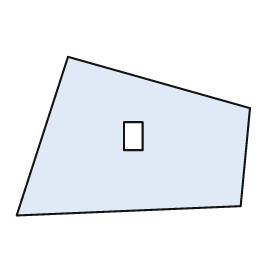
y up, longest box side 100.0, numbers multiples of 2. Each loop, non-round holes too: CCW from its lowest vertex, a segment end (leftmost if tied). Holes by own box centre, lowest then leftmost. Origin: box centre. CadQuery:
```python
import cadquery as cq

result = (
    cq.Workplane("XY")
    .moveTo(-50.0, -34.0)
    .lineTo(46.0, -30.0)
    .lineTo(50.0, 12.0)
    .lineTo(-28.0, 34.0)
    .close()
    .moveTo(-4.0, -6.0)
    .lineTo(4.0, -6.0)
    .lineTo(4.0, 6.0)
    .lineTo(-4.0, 6.0)
    .close()
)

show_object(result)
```